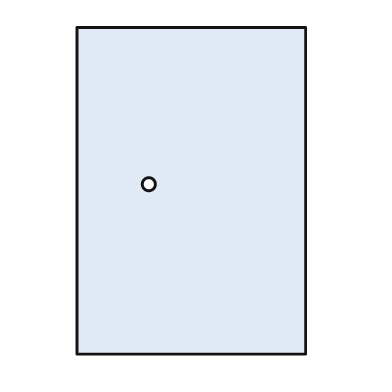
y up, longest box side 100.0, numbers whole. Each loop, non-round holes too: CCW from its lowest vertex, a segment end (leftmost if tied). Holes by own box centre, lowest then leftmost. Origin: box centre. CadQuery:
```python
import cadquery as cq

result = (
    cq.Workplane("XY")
    .moveTo(-35.0, -50.0)
    .lineTo(35.0, -50.0)
    .lineTo(35.0, 50.0)
    .lineTo(-35.0, 50.0)
    .close()
    .moveTo(-13.0, 2.0)
    .circle(2.0)
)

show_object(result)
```